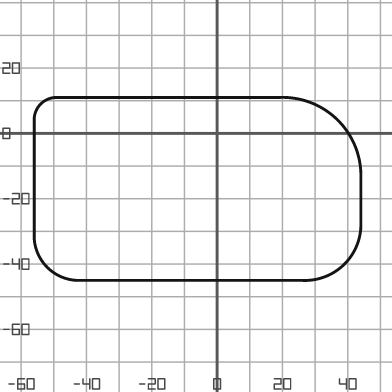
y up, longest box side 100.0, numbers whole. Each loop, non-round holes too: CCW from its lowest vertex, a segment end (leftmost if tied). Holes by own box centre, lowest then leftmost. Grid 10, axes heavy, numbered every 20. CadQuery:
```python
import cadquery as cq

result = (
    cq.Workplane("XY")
    .moveTo(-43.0, -45.0)
    .lineTo(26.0, -45.0)
    .threePointArc((39.0, -40.0), (44.0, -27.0))
    .lineTo(44.0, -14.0)
    .threePointArc((37.0, 4.0), (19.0, 11.0))
    .lineTo(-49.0, 11.0)
    .threePointArc((-54.0, 9.0), (-56.0, 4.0))
    .lineTo(-56.0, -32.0)
    .threePointArc((-52.0, -41.0), (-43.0, -45.0))
    .close()
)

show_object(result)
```